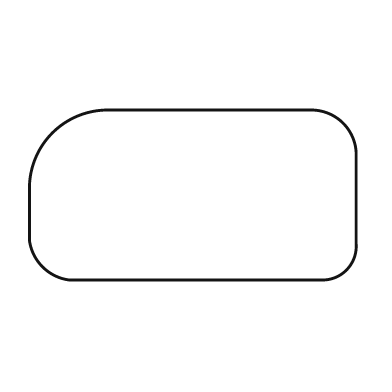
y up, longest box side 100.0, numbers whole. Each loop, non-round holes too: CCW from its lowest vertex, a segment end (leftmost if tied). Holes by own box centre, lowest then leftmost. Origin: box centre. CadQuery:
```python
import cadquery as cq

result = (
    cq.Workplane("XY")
    .moveTo(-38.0, -26.0)
    .lineTo(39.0, -26.0)
    .threePointArc((47.0, -23.0), (50.0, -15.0))
    .lineTo(50.0, 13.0)
    .threePointArc((46.0, 22.0), (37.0, 26.0))
    .lineTo(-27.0, 26.0)
    .threePointArc((-43.0, 19.0), (-50.0, 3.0))
    .lineTo(-50.0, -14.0)
    .threePointArc((-46.0, -22.0), (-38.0, -26.0))
    .close()
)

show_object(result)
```